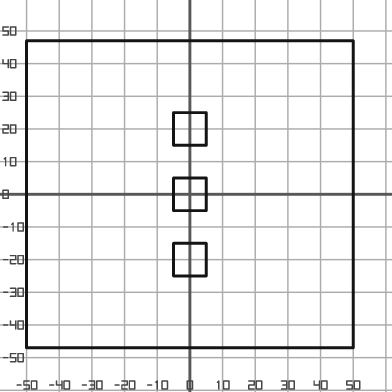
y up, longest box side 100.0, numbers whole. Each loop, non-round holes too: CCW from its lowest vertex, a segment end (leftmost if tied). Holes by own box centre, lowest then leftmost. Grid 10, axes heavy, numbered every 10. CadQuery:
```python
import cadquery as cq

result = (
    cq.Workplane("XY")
    .moveTo(-50.0, -47.0)
    .lineTo(50.0, -47.0)
    .lineTo(50.0, 47.0)
    .lineTo(-50.0, 47.0)
    .close()
    .moveTo(-5.0, -25.0)
    .lineTo(5.0, -25.0)
    .lineTo(5.0, -15.0)
    .lineTo(-5.0, -15.0)
    .close()
    .moveTo(-5.0, -5.0)
    .lineTo(5.0, -5.0)
    .lineTo(5.0, 5.0)
    .lineTo(-5.0, 5.0)
    .close()
    .moveTo(-5.0, 15.0)
    .lineTo(5.0, 15.0)
    .lineTo(5.0, 25.0)
    .lineTo(-5.0, 25.0)
    .close()
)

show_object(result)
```